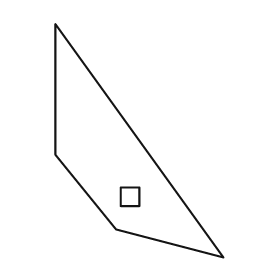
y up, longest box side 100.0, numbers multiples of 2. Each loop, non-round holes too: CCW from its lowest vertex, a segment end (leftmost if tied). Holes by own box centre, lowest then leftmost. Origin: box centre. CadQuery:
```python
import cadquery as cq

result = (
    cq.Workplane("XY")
    .moveTo(36.0, -50.0)
    .lineTo(-36.0, 50.0)
    .lineTo(-36.0, -6.0)
    .lineTo(-10.0, -38.0)
    .close()
    .moveTo(-8.0, -28.0)
    .lineTo(0.0, -28.0)
    .lineTo(0.0, -20.0)
    .lineTo(-8.0, -20.0)
    .close()
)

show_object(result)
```